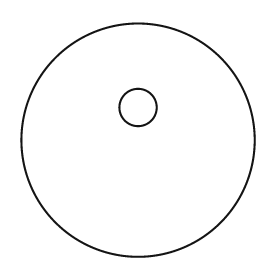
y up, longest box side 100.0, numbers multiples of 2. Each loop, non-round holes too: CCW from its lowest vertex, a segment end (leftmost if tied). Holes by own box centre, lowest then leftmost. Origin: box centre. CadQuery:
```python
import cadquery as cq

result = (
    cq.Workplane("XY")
    .moveTo(0.0, 0.0)
    .circle(50.0)
    .moveTo(0.0, 14.0)
    .circle(8.0)
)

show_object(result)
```